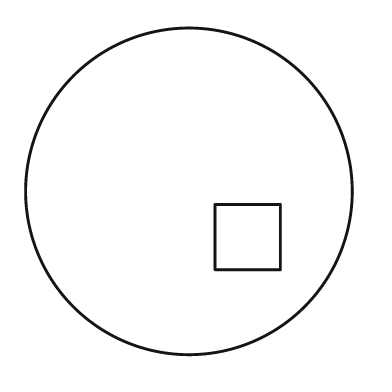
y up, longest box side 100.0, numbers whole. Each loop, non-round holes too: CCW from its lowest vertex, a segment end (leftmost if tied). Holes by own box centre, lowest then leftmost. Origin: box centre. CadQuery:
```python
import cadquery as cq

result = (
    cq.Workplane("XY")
    .moveTo(0.0, 0.0)
    .circle(50.0)
    .moveTo(8.0, -24.0)
    .lineTo(28.0, -24.0)
    .lineTo(28.0, -4.0)
    .lineTo(8.0, -4.0)
    .close()
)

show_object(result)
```